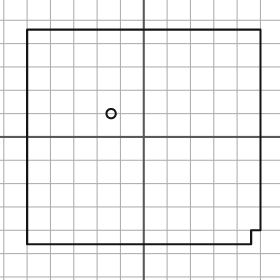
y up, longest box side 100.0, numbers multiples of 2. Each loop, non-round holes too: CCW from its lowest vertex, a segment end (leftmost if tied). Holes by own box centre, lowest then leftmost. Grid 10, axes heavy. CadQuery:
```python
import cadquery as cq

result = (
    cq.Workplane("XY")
    .moveTo(-50.0, -46.0)
    .lineTo(46.0, -46.0)
    .lineTo(46.0, -40.0)
    .lineTo(50.0, -40.0)
    .lineTo(50.0, 46.0)
    .lineTo(-50.0, 46.0)
    .close()
    .moveTo(-14.0, 10.0)
    .circle(2.0)
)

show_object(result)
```